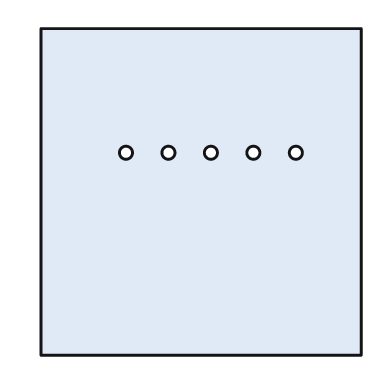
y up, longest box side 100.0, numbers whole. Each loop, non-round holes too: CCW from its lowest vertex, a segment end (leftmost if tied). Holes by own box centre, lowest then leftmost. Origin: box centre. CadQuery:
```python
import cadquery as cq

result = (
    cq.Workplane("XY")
    .moveTo(-49.0, -50.0)
    .lineTo(49.0, -50.0)
    .lineTo(49.0, 50.0)
    .lineTo(-49.0, 50.0)
    .close()
    .moveTo(-23.0, 12.0)
    .circle(2.0)
    .moveTo(-10.0, 12.0)
    .circle(2.0)
    .moveTo(3.0, 12.0)
    .circle(2.0)
    .moveTo(16.0, 12.0)
    .circle(2.0)
    .moveTo(29.0, 12.0)
    .circle(2.0)
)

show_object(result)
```